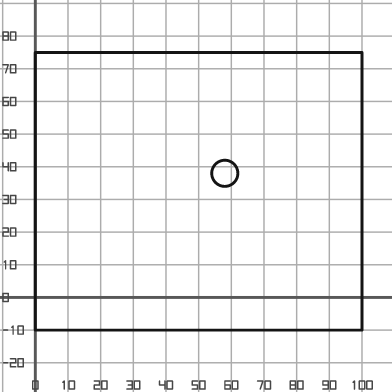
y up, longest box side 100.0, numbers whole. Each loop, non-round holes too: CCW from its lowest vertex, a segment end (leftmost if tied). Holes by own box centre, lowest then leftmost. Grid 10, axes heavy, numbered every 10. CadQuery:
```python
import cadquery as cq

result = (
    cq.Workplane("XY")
    .moveTo(0.0, -10.0)
    .lineTo(100.0, -10.0)
    .lineTo(100.0, 75.0)
    .lineTo(0.0, 75.0)
    .close()
    .moveTo(58.0, 38.0)
    .circle(4.0)
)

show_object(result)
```